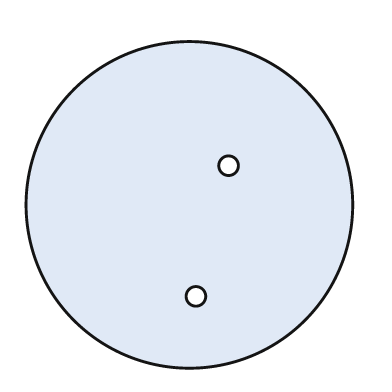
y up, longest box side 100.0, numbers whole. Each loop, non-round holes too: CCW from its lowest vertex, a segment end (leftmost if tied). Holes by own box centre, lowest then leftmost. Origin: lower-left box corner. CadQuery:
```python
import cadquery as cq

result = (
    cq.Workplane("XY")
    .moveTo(50.0, 50.0)
    .circle(50.0)
    .moveTo(52.0, 22.0)
    .circle(3.0)
    .moveTo(62.0, 62.0)
    .circle(3.0)
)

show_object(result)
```